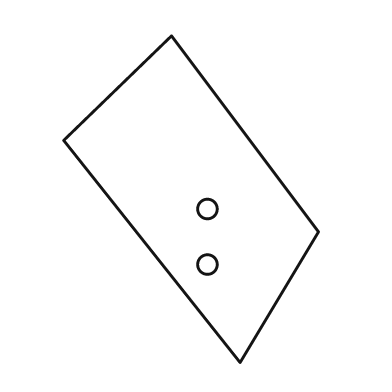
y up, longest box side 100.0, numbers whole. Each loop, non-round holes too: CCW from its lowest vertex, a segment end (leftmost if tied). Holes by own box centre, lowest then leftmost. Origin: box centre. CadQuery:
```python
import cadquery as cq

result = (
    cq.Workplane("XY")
    .moveTo(15.0, -50.0)
    .lineTo(39.0, -10.0)
    .lineTo(-6.0, 50.0)
    .lineTo(-39.0, 18.0)
    .close()
    .moveTo(5.0, -20.0)
    .circle(3.0)
    .moveTo(5.0, -3.0)
    .circle(3.0)
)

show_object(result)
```